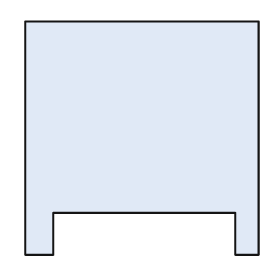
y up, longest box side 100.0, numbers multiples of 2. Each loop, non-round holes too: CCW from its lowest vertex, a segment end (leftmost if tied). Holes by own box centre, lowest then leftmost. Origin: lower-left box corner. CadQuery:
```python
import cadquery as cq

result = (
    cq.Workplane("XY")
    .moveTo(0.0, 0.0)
    .lineTo(12.0, 0.0)
    .lineTo(12.0, 18.0)
    .lineTo(90.0, 18.0)
    .lineTo(90.0, 0.0)
    .lineTo(100.0, 0.0)
    .lineTo(100.0, 100.0)
    .lineTo(0.0, 100.0)
    .close()
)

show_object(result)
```